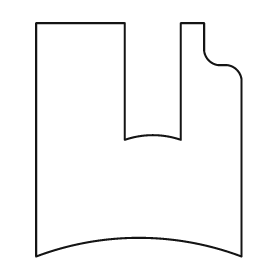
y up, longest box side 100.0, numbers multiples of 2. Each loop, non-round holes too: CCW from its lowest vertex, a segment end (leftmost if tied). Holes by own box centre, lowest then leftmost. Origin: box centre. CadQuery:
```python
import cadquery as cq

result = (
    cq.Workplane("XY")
    .moveTo(-44.0, -50.0)
    .threePointArc((0.0, -42.0), (44.0, -50.0))
    .lineTo(44.0, 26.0)
    .threePointArc((42.0, 30.0), (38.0, 32.0))
    .lineTo(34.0, 32.0)
    .threePointArc((30.0, 34.0), (28.0, 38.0))
    .lineTo(28.0, 50.0)
    .lineTo(18.0, 50.0)
    .lineTo(18.0, 0.0)
    .threePointArc((6.0, 2.0), (-6.0, 0.0))
    .lineTo(-6.0, 50.0)
    .lineTo(-44.0, 50.0)
    .close()
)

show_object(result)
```